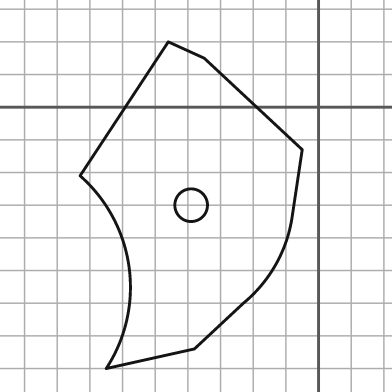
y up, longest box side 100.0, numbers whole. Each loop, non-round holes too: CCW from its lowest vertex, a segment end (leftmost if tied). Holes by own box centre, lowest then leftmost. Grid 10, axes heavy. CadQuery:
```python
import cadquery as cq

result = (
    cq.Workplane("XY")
    .moveTo(-65.0, -80.0)
    .lineTo(-38.0, -74.0)
    .lineTo(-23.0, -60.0)
    .threePointArc((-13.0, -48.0), (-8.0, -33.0))
    .lineTo(-5.0, -13.0)
    .lineTo(-35.0, 15.0)
    .lineTo(-46.0, 20.0)
    .lineTo(-73.0, -21.0)
    .threePointArc((-58.0, -49.0), (-65.0, -80.0))
    .close()
    .moveTo(-39.0, -30.0)
    .circle(5.0)
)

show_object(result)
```